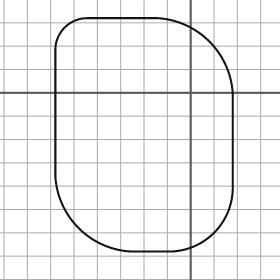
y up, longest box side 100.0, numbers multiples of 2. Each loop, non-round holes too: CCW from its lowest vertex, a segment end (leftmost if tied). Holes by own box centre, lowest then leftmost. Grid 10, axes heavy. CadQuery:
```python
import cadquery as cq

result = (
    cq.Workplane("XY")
    .moveTo(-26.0, -68.0)
    .lineTo(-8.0, -68.0)
    .threePointArc((10.0, -60.0), (18.0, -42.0))
    .lineTo(18.0, 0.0)
    .threePointArc((8.0, 22.0), (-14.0, 32.0))
    .lineTo(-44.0, 32.0)
    .threePointArc((-54.0, 28.0), (-58.0, 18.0))
    .lineTo(-58.0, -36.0)
    .threePointArc((-48.0, -58.0), (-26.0, -68.0))
    .close()
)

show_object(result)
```